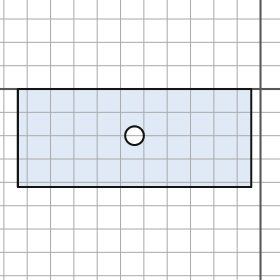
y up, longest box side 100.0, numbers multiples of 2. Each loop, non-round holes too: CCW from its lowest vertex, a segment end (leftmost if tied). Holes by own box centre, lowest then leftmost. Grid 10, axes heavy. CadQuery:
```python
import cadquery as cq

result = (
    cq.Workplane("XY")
    .moveTo(-104.0, -42.0)
    .lineTo(-4.0, -42.0)
    .lineTo(-4.0, 0.0)
    .lineTo(-104.0, 0.0)
    .close()
    .moveTo(-54.0, -20.0)
    .circle(4.0)
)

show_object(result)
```